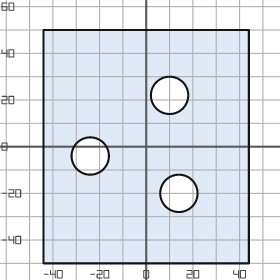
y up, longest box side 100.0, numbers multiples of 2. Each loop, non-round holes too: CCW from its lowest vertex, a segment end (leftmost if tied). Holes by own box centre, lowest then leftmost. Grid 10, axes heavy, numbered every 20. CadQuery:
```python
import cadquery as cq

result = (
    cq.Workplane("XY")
    .moveTo(-44.0, -50.0)
    .lineTo(44.0, -50.0)
    .lineTo(44.0, 50.0)
    .lineTo(-44.0, 50.0)
    .close()
    .moveTo(14.0, -20.0)
    .circle(8.0)
    .moveTo(-24.0, -4.0)
    .circle(8.0)
    .moveTo(10.0, 22.0)
    .circle(8.0)
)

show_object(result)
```